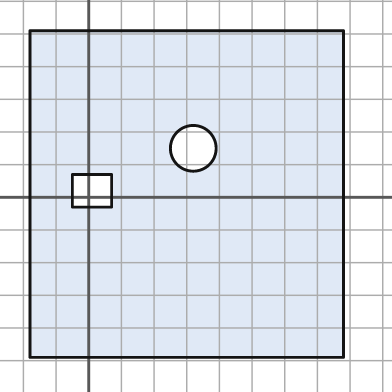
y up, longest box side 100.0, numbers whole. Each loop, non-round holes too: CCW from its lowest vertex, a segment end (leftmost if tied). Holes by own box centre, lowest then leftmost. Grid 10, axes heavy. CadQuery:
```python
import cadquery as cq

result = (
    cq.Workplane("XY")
    .moveTo(-18.0, -49.0)
    .lineTo(78.0, -49.0)
    .lineTo(78.0, 51.0)
    .lineTo(-18.0, 51.0)
    .close()
    .moveTo(-5.0, -3.0)
    .lineTo(7.0, -3.0)
    .lineTo(7.0, 7.0)
    .lineTo(-5.0, 7.0)
    .close()
    .moveTo(32.0, 15.0)
    .circle(7.0)
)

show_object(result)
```